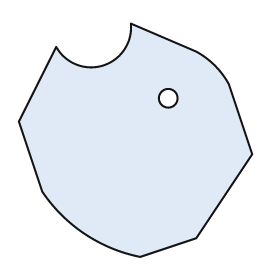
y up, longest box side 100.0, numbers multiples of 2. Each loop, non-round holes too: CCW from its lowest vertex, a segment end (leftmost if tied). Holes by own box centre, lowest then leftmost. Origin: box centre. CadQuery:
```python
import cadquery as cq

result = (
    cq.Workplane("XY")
    .moveTo(2.0, -50.0)
    .lineTo(26.0, -42.0)
    .lineTo(50.0, -6.0)
    .lineTo(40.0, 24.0)
    .threePointArc((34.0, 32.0), (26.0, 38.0))
    .lineTo(-2.0, 50.0)
    .threePointArc((-14.0, 32.0), (-34.0, 40.0))
    .lineTo(-50.0, 8.0)
    .lineTo(-40.0, -22.0)
    .threePointArc((-22.0, -40.0), (2.0, -50.0))
    .close()
    .moveTo(14.0, 18.0)
    .circle(4.0)
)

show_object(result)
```